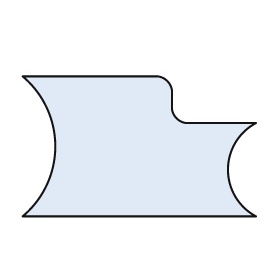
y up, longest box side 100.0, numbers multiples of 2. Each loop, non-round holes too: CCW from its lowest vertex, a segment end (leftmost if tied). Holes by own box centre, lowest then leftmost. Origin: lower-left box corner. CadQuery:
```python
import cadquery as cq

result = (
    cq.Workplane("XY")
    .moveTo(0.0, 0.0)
    .lineTo(100.0, 0.0)
    .threePointArc((88.0, 20.0), (100.0, 40.0))
    .lineTo(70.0, 40.0)
    .threePointArc((66.0, 42.0), (64.0, 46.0))
    .lineTo(64.0, 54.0)
    .threePointArc((62.0, 58.0), (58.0, 60.0))
    .lineTo(0.0, 60.0)
    .threePointArc((14.0, 30.0), (0.0, 0.0))
    .close()
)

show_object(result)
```